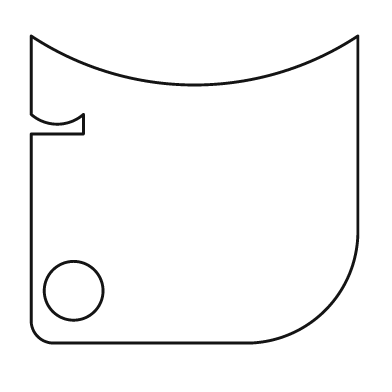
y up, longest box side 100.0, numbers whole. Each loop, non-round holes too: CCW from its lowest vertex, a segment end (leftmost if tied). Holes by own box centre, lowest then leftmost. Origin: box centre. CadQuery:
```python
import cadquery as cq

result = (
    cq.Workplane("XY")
    .moveTo(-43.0, -47.0)
    .lineTo(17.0, -47.0)
    .threePointArc((40.0, -37.0), (50.0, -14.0))
    .lineTo(50.0, 47.0)
    .threePointArc((0.0, 32.0), (-50.0, 47.0))
    .lineTo(-50.0, 23.0)
    .threePointArc((-42.0, 20.0), (-34.0, 23.0))
    .lineTo(-34.0, 17.0)
    .lineTo(-50.0, 17.0)
    .lineTo(-50.0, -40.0)
    .threePointArc((-48.0, -45.0), (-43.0, -47.0))
    .close()
    .moveTo(-37.0, -31.0)
    .circle(9.0)
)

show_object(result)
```